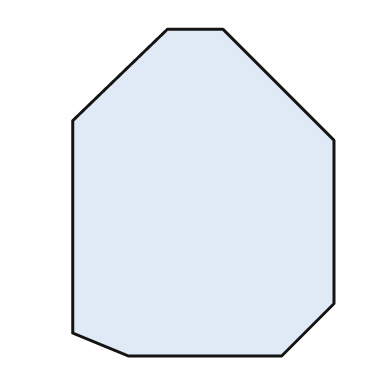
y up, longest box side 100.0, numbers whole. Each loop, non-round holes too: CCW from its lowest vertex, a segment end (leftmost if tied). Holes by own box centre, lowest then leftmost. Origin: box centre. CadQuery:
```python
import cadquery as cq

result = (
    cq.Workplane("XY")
    .moveTo(-23.0, -50.0)
    .lineTo(24.0, -50.0)
    .lineTo(40.0, -34.0)
    .lineTo(40.0, 16.0)
    .lineTo(6.0, 50.0)
    .lineTo(-11.0, 50.0)
    .lineTo(-40.0, 22.0)
    .lineTo(-40.0, -43.0)
    .close()
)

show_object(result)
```